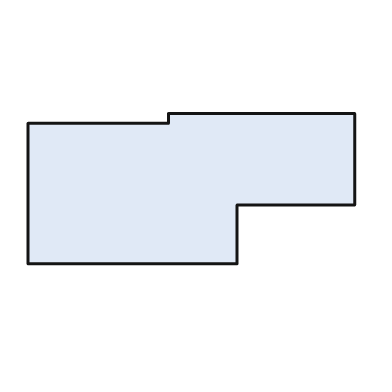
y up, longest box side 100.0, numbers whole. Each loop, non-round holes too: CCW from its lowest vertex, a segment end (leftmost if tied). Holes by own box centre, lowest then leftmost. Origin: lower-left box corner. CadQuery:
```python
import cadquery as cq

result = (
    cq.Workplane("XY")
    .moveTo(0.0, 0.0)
    .lineTo(64.0, 0.0)
    .lineTo(64.0, 18.0)
    .lineTo(100.0, 18.0)
    .lineTo(100.0, 46.0)
    .lineTo(43.0, 46.0)
    .lineTo(43.0, 43.0)
    .lineTo(0.0, 43.0)
    .close()
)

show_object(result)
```